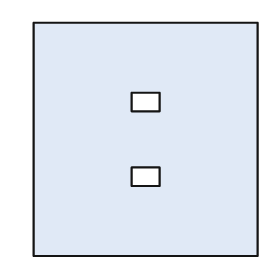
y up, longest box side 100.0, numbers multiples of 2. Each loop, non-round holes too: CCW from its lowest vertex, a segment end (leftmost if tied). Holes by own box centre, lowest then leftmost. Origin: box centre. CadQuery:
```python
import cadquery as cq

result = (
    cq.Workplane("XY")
    .moveTo(-48.0, -50.0)
    .lineTo(48.0, -50.0)
    .lineTo(48.0, 50.0)
    .lineTo(-48.0, 50.0)
    .close()
    .moveTo(-6.0, -20.0)
    .lineTo(6.0, -20.0)
    .lineTo(6.0, -12.0)
    .lineTo(-6.0, -12.0)
    .close()
    .moveTo(-6.0, 12.0)
    .lineTo(6.0, 12.0)
    .lineTo(6.0, 20.0)
    .lineTo(-6.0, 20.0)
    .close()
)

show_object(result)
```